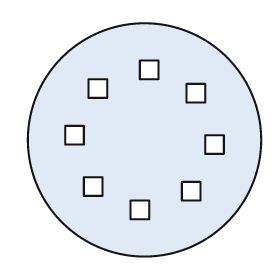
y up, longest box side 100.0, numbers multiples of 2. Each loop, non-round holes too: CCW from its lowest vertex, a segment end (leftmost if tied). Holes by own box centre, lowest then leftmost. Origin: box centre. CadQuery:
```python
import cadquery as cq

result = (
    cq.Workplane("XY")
    .moveTo(0.0, 0.0)
    .circle(50.0)
    .moveTo(-6.0, -34.0)
    .lineTo(2.0, -34.0)
    .lineTo(2.0, -26.0)
    .lineTo(-6.0, -26.0)
    .close()
    .moveTo(16.0, -26.0)
    .lineTo(24.0, -26.0)
    .lineTo(24.0, -18.0)
    .lineTo(16.0, -18.0)
    .close()
    .moveTo(-26.0, -24.0)
    .lineTo(-18.0, -24.0)
    .lineTo(-18.0, -16.0)
    .lineTo(-26.0, -16.0)
    .close()
    .moveTo(26.0, -6.0)
    .lineTo(34.0, -6.0)
    .lineTo(34.0, 2.0)
    .lineTo(26.0, 2.0)
    .close()
    .moveTo(-34.0, -2.0)
    .lineTo(-26.0, -2.0)
    .lineTo(-26.0, 6.0)
    .lineTo(-34.0, 6.0)
    .close()
    .moveTo(18.0, 16.0)
    .lineTo(26.0, 16.0)
    .lineTo(26.0, 24.0)
    .lineTo(18.0, 24.0)
    .close()
    .moveTo(-24.0, 18.0)
    .lineTo(-16.0, 18.0)
    .lineTo(-16.0, 26.0)
    .lineTo(-24.0, 26.0)
    .close()
    .moveTo(-2.0, 26.0)
    .lineTo(6.0, 26.0)
    .lineTo(6.0, 34.0)
    .lineTo(-2.0, 34.0)
    .close()
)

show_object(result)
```